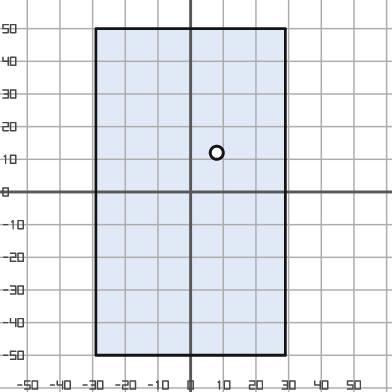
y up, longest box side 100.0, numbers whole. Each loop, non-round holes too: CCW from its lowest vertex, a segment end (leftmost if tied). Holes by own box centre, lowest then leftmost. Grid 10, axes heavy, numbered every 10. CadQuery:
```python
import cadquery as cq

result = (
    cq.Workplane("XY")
    .moveTo(-29.0, -50.0)
    .lineTo(29.0, -50.0)
    .lineTo(29.0, 50.0)
    .lineTo(-29.0, 50.0)
    .close()
    .moveTo(8.0, 12.0)
    .circle(2.0)
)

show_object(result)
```